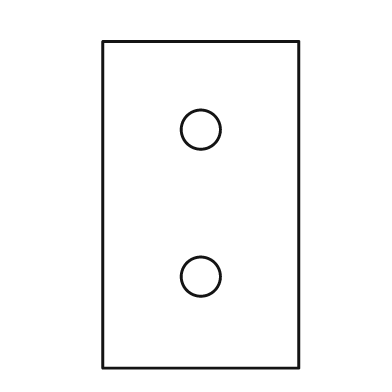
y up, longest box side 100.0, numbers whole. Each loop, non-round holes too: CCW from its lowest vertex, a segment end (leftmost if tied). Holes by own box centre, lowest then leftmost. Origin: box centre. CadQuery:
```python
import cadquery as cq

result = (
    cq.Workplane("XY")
    .moveTo(-30.0, -50.0)
    .lineTo(30.0, -50.0)
    .lineTo(30.0, 50.0)
    .lineTo(-30.0, 50.0)
    .close()
    .moveTo(0.0, -22.0)
    .circle(6.0)
    .moveTo(0.0, 23.0)
    .circle(6.0)
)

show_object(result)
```